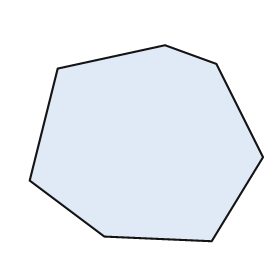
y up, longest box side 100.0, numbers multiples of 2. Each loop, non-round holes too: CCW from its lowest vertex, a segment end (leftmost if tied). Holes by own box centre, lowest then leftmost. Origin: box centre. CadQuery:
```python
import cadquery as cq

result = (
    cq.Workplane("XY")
    .moveTo(28.0, -42.0)
    .lineTo(50.0, -6.0)
    .lineTo(30.0, 34.0)
    .lineTo(8.0, 42.0)
    .lineTo(-38.0, 32.0)
    .lineTo(-50.0, -16.0)
    .lineTo(-18.0, -40.0)
    .close()
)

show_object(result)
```